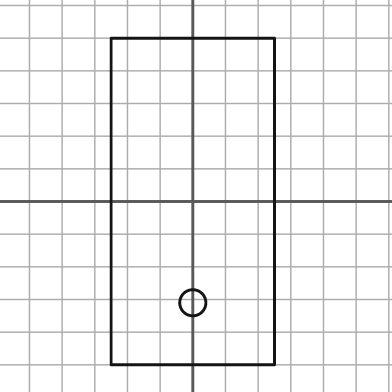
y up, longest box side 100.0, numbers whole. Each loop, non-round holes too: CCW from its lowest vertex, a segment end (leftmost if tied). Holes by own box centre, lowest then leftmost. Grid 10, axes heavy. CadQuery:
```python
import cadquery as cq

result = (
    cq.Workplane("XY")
    .moveTo(-25.0, -50.0)
    .lineTo(25.0, -50.0)
    .lineTo(25.0, 50.0)
    .lineTo(-25.0, 50.0)
    .close()
    .moveTo(0.0, -31.0)
    .circle(4.0)
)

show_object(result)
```